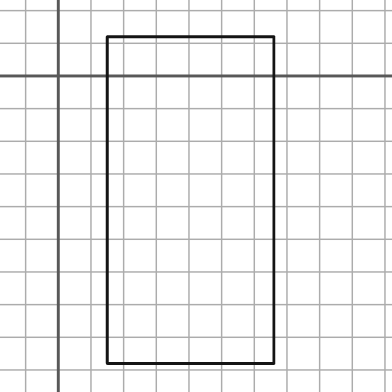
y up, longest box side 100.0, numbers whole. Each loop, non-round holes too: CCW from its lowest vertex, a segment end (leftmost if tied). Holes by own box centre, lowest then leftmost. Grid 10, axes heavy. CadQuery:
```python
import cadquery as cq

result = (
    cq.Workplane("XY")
    .moveTo(15.0, -88.0)
    .lineTo(66.0, -88.0)
    .lineTo(66.0, 12.0)
    .lineTo(15.0, 12.0)
    .close()
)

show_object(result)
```